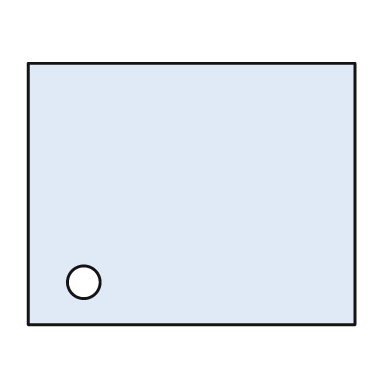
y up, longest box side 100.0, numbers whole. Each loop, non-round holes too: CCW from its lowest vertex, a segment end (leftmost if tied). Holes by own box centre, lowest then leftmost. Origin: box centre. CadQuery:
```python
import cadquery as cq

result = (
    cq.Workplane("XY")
    .moveTo(-50.0, -40.0)
    .lineTo(50.0, -40.0)
    .lineTo(50.0, 40.0)
    .lineTo(-50.0, 40.0)
    .close()
    .moveTo(-33.0, -27.0)
    .circle(5.0)
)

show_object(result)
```